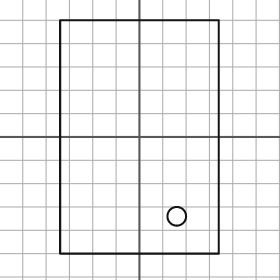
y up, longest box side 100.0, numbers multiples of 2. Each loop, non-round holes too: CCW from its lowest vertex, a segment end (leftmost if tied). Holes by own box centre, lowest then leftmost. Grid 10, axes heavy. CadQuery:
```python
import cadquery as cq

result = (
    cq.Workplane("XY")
    .moveTo(-34.0, -50.0)
    .lineTo(34.0, -50.0)
    .lineTo(34.0, 50.0)
    .lineTo(-34.0, 50.0)
    .close()
    .moveTo(16.0, -34.0)
    .circle(4.0)
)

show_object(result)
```